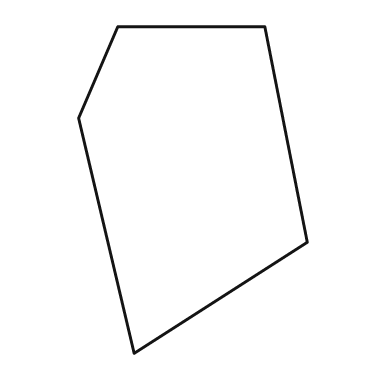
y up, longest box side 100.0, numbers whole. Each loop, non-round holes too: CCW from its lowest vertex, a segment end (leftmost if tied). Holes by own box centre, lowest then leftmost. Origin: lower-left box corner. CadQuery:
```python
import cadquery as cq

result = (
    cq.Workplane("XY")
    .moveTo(17.0, 0.0)
    .lineTo(70.0, 34.0)
    .lineTo(57.0, 100.0)
    .lineTo(12.0, 100.0)
    .lineTo(0.0, 72.0)
    .close()
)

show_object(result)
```